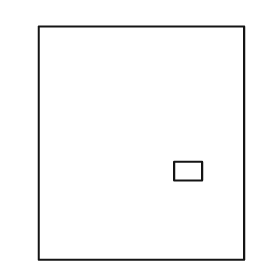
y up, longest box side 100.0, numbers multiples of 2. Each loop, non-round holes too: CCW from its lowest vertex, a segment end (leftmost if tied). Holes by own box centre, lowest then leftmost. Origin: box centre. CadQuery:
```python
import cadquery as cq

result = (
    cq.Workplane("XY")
    .moveTo(-44.0, -50.0)
    .lineTo(44.0, -50.0)
    .lineTo(44.0, 50.0)
    .lineTo(-44.0, 50.0)
    .close()
    .moveTo(14.0, -16.0)
    .lineTo(26.0, -16.0)
    .lineTo(26.0, -8.0)
    .lineTo(14.0, -8.0)
    .close()
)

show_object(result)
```